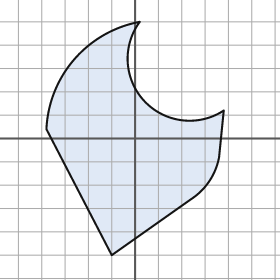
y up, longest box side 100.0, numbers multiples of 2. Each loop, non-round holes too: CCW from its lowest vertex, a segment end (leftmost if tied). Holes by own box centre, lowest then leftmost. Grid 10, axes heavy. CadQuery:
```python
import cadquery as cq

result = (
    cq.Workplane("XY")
    .moveTo(-10.0, -50.0)
    .lineTo(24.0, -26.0)
    .threePointArc((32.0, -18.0), (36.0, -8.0))
    .lineTo(38.0, 12.0)
    .threePointArc((4.0, 16.0), (2.0, 50.0))
    .threePointArc((-26.0, 34.0), (-38.0, 4.0))
    .close()
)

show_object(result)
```